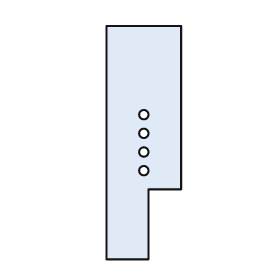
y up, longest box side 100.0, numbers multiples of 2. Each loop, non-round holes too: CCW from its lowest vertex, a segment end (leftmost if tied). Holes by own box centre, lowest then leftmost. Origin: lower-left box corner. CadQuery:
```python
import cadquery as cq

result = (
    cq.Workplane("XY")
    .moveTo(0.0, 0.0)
    .lineTo(18.0, 0.0)
    .lineTo(18.0, 30.0)
    .lineTo(32.0, 30.0)
    .lineTo(32.0, 100.0)
    .lineTo(0.0, 100.0)
    .close()
    .moveTo(16.0, 38.0)
    .circle(2.0)
    .moveTo(16.0, 46.0)
    .circle(2.0)
    .moveTo(16.0, 54.0)
    .circle(2.0)
    .moveTo(16.0, 62.0)
    .circle(2.0)
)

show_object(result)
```